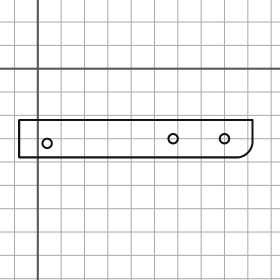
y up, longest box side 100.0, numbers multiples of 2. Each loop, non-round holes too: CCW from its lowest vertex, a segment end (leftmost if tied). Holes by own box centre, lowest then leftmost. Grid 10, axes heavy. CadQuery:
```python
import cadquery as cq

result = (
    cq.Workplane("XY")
    .moveTo(-8.0, -38.0)
    .lineTo(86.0, -38.0)
    .threePointArc((90.0, -36.0), (92.0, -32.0))
    .lineTo(92.0, -22.0)
    .lineTo(-8.0, -22.0)
    .close()
    .moveTo(4.0, -32.0)
    .circle(2.0)
    .moveTo(58.0, -30.0)
    .circle(2.0)
    .moveTo(80.0, -30.0)
    .circle(2.0)
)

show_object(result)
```